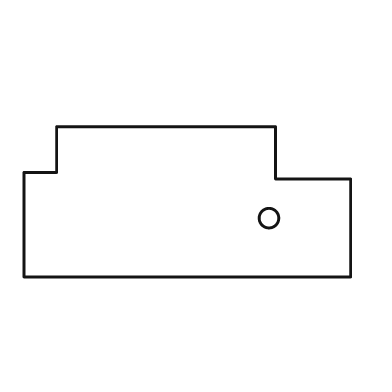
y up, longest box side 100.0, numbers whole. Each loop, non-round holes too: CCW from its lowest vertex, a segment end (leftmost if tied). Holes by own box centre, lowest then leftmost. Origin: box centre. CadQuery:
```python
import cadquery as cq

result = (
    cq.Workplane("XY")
    .moveTo(-50.0, -23.0)
    .lineTo(50.0, -23.0)
    .lineTo(50.0, 7.0)
    .lineTo(27.0, 7.0)
    .lineTo(27.0, 23.0)
    .lineTo(-40.0, 23.0)
    .lineTo(-40.0, 9.0)
    .lineTo(-50.0, 9.0)
    .close()
    .moveTo(25.0, -5.0)
    .circle(3.0)
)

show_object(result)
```